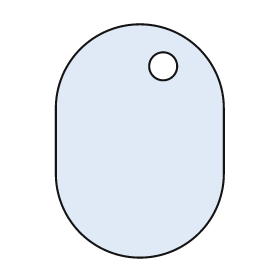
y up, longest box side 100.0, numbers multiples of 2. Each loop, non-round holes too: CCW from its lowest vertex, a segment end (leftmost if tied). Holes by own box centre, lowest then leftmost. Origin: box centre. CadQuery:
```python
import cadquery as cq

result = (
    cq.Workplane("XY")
    .moveTo(-36.0, -14.0)
    .threePointArc((0.0, -50.0), (36.0, -14.0))
    .lineTo(36.0, 14.0)
    .threePointArc((0.0, 50.0), (-36.0, 14.0))
    .close()
    .moveTo(10.0, 32.0)
    .circle(6.0)
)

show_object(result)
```